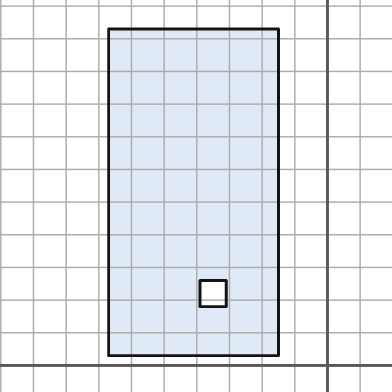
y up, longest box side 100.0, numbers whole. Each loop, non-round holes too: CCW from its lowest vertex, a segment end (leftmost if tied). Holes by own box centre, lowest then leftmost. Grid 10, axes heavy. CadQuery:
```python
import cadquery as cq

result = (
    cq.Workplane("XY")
    .moveTo(-67.0, 3.0)
    .lineTo(-15.0, 3.0)
    .lineTo(-15.0, 103.0)
    .lineTo(-67.0, 103.0)
    .close()
    .moveTo(-39.0, 18.0)
    .lineTo(-31.0, 18.0)
    .lineTo(-31.0, 26.0)
    .lineTo(-39.0, 26.0)
    .close()
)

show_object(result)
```